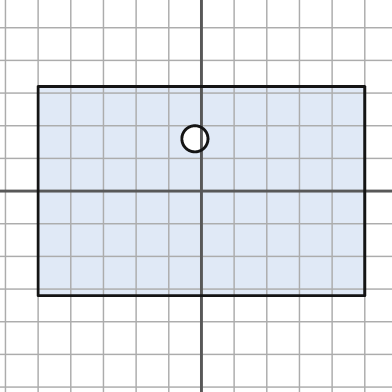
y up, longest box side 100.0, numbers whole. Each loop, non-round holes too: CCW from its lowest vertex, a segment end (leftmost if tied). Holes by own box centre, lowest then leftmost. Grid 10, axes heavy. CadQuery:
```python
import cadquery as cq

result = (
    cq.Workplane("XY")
    .moveTo(-50.0, -32.0)
    .lineTo(50.0, -32.0)
    .lineTo(50.0, 32.0)
    .lineTo(-50.0, 32.0)
    .close()
    .moveTo(-2.0, 16.0)
    .circle(4.0)
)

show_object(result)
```